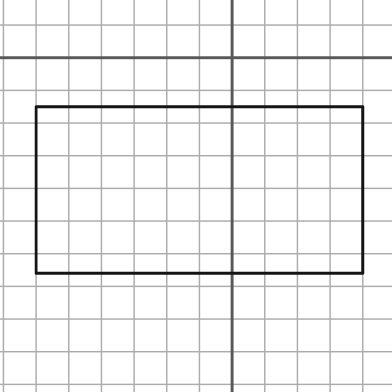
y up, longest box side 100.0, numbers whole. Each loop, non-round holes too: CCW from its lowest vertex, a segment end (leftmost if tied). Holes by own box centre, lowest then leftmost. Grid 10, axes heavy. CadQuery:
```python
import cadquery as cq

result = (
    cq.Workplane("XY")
    .moveTo(-60.0, -66.0)
    .lineTo(40.0, -66.0)
    .lineTo(40.0, -15.0)
    .lineTo(-60.0, -15.0)
    .close()
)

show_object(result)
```